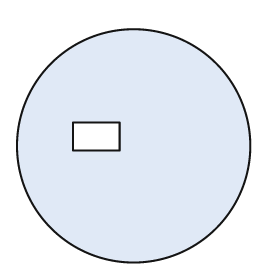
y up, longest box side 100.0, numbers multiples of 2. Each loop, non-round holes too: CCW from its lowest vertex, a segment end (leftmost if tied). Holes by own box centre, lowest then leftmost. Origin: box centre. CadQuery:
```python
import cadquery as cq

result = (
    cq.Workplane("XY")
    .moveTo(0.0, 0.0)
    .circle(50.0)
    .moveTo(-26.0, -2.0)
    .lineTo(-6.0, -2.0)
    .lineTo(-6.0, 10.0)
    .lineTo(-26.0, 10.0)
    .close()
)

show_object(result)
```